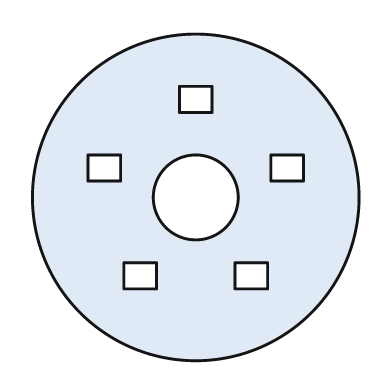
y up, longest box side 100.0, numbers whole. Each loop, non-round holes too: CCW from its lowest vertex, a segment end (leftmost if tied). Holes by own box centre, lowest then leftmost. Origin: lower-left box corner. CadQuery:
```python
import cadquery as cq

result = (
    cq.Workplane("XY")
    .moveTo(50.0, 50.0)
    .circle(50.0)
    .moveTo(28.0, 22.0)
    .lineTo(38.0, 22.0)
    .lineTo(38.0, 30.0)
    .lineTo(28.0, 30.0)
    .close()
    .moveTo(62.0, 22.0)
    .lineTo(72.0, 22.0)
    .lineTo(72.0, 30.0)
    .lineTo(62.0, 30.0)
    .close()
    .moveTo(50.0, 50.0)
    .circle(13.0)
    .moveTo(17.0, 55.0)
    .lineTo(27.0, 55.0)
    .lineTo(27.0, 63.0)
    .lineTo(17.0, 63.0)
    .close()
    .moveTo(73.0, 55.0)
    .lineTo(83.0, 55.0)
    .lineTo(83.0, 63.0)
    .lineTo(73.0, 63.0)
    .close()
    .moveTo(45.0, 76.0)
    .lineTo(55.0, 76.0)
    .lineTo(55.0, 84.0)
    .lineTo(45.0, 84.0)
    .close()
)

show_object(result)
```